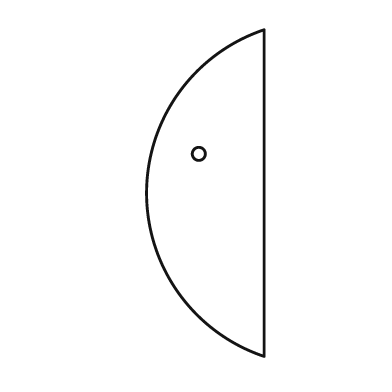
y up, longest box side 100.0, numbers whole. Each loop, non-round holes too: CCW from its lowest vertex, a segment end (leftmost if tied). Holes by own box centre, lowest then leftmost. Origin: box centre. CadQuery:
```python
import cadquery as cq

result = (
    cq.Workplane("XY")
    .moveTo(18.0, -50.0)
    .lineTo(18.0, 50.0)
    .threePointArc((-18.0, 0.0), (18.0, -50.0))
    .close()
    .moveTo(-2.0, 12.0)
    .circle(2.0)
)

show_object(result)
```